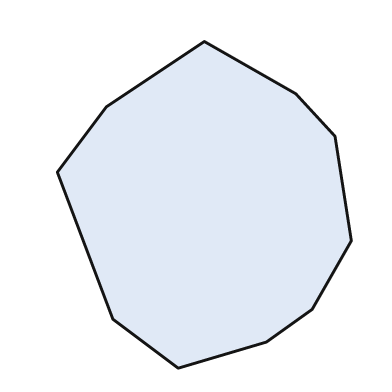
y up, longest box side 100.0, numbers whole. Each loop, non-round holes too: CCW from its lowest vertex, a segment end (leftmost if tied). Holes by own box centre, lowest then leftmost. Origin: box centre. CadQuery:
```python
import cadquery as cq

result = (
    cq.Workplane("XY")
    .moveTo(-8.0, -50.0)
    .lineTo(19.0, -42.0)
    .lineTo(33.0, -32.0)
    .lineTo(45.0, -11.0)
    .lineTo(40.0, 21.0)
    .lineTo(28.0, 34.0)
    .lineTo(0.0, 50.0)
    .lineTo(-30.0, 30.0)
    .lineTo(-45.0, 10.0)
    .lineTo(-28.0, -35.0)
    .close()
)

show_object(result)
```